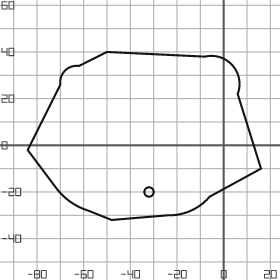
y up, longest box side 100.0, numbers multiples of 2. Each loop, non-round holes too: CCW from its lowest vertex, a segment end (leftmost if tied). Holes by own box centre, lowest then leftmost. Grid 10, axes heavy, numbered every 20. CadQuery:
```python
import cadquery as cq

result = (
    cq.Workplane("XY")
    .moveTo(-48.0, -32.0)
    .lineTo(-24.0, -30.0)
    .threePointArc((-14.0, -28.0), (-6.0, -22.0))
    .lineTo(16.0, -10.0)
    .lineTo(6.0, 22.0)
    .threePointArc((4.0, 34.0), (-8.0, 38.0))
    .lineTo(-50.0, 40.0)
    .lineTo(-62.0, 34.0)
    .threePointArc((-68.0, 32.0), (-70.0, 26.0))
    .lineTo(-84.0, -2.0)
    .lineTo(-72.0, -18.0)
    .threePointArc((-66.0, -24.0), (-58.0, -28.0))
    .close()
    .moveTo(-32.0, -20.0)
    .circle(2.0)
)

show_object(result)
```